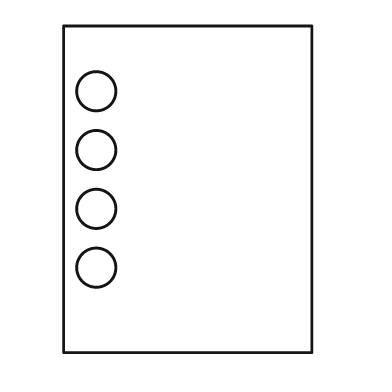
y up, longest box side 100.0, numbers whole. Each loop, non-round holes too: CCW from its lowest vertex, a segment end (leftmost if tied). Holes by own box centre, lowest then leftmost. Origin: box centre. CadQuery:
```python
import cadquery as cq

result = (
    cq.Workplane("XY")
    .moveTo(-38.0, -50.0)
    .lineTo(38.0, -50.0)
    .lineTo(38.0, 50.0)
    .lineTo(-38.0, 50.0)
    .close()
    .moveTo(-28.0, -24.0)
    .circle(6.0)
    .moveTo(-28.0, -6.0)
    .circle(6.0)
    .moveTo(-28.0, 12.0)
    .circle(6.0)
    .moveTo(-28.0, 30.0)
    .circle(6.0)
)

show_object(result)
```